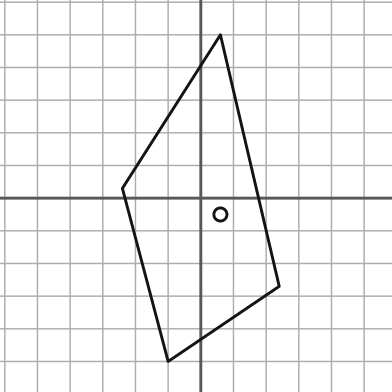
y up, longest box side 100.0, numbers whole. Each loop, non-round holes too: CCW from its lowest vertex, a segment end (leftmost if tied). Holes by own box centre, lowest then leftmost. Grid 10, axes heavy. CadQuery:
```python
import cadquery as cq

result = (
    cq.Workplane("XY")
    .moveTo(-10.0, -50.0)
    .lineTo(24.0, -27.0)
    .lineTo(6.0, 50.0)
    .lineTo(-24.0, 3.0)
    .close()
    .moveTo(6.0, -5.0)
    .circle(2.0)
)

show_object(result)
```